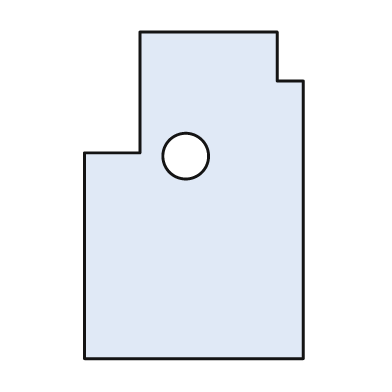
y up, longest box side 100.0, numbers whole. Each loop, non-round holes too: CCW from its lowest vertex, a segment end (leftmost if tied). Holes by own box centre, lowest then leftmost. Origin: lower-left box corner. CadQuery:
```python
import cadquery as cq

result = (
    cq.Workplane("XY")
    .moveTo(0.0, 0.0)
    .lineTo(67.0, 0.0)
    .lineTo(67.0, 85.0)
    .lineTo(59.0, 85.0)
    .lineTo(59.0, 100.0)
    .lineTo(17.0, 100.0)
    .lineTo(17.0, 63.0)
    .lineTo(0.0, 63.0)
    .close()
    .moveTo(31.0, 62.0)
    .circle(7.0)
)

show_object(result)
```